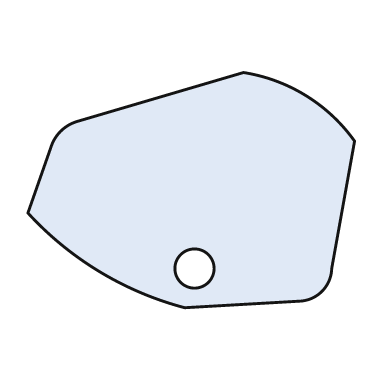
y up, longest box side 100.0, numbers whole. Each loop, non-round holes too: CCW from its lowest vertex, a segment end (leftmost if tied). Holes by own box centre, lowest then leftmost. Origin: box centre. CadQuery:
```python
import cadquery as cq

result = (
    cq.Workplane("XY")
    .moveTo(-2.0, -36.0)
    .lineTo(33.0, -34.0)
    .threePointArc((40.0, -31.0), (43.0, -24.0))
    .lineTo(50.0, 15.0)
    .threePointArc((35.0, 29.0), (16.0, 36.0))
    .lineTo(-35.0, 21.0)
    .threePointArc((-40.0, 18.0), (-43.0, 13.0))
    .lineTo(-50.0, -7.0)
    .threePointArc((-28.0, -25.0), (-2.0, -36.0))
    .close()
    .moveTo(1.0, -24.0)
    .circle(6.0)
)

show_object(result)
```